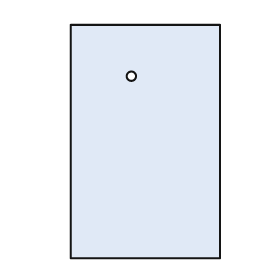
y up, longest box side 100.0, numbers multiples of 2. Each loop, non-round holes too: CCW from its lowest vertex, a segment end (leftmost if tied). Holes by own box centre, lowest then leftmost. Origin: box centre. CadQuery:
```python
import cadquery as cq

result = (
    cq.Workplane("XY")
    .moveTo(-32.0, -50.0)
    .lineTo(32.0, -50.0)
    .lineTo(32.0, 50.0)
    .lineTo(-32.0, 50.0)
    .close()
    .moveTo(-6.0, 28.0)
    .circle(2.0)
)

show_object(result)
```